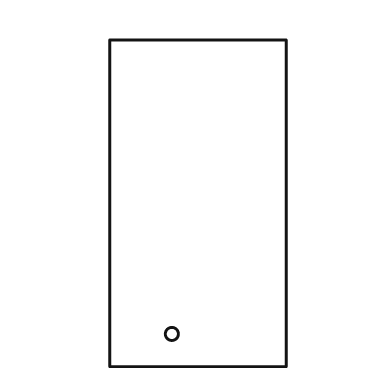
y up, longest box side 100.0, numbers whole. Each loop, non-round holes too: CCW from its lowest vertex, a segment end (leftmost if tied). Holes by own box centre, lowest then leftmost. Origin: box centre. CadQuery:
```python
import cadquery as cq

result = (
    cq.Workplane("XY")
    .moveTo(-27.0, -50.0)
    .lineTo(27.0, -50.0)
    .lineTo(27.0, 50.0)
    .lineTo(-27.0, 50.0)
    .close()
    .moveTo(-8.0, -40.0)
    .circle(2.0)
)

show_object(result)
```